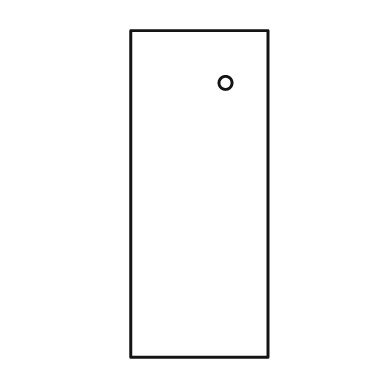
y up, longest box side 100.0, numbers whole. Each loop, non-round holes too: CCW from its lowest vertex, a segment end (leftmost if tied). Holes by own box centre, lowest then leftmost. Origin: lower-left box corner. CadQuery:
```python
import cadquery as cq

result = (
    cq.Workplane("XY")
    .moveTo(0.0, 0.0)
    .lineTo(42.0, 0.0)
    .lineTo(42.0, 100.0)
    .lineTo(0.0, 100.0)
    .close()
    .moveTo(29.0, 84.0)
    .circle(2.0)
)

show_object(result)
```